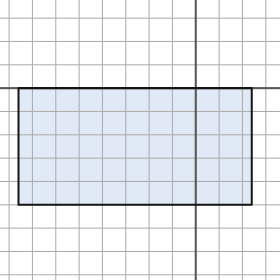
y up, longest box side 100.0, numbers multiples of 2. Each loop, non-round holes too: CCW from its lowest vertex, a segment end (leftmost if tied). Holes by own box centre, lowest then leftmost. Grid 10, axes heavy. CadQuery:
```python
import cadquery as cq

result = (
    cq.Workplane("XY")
    .moveTo(-76.0, -50.0)
    .lineTo(24.0, -50.0)
    .lineTo(24.0, 0.0)
    .lineTo(-76.0, 0.0)
    .close()
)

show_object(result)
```